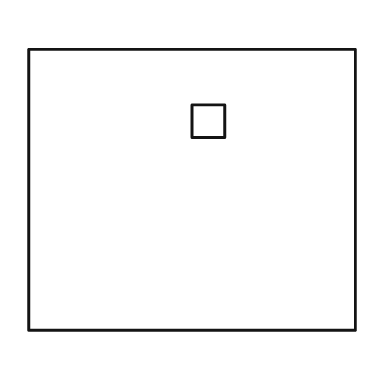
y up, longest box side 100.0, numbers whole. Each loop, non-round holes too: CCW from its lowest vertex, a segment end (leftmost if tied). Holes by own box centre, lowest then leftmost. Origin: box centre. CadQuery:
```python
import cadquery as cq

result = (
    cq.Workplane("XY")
    .moveTo(-50.0, -43.0)
    .lineTo(50.0, -43.0)
    .lineTo(50.0, 43.0)
    .lineTo(-50.0, 43.0)
    .close()
    .moveTo(0.0, 16.0)
    .lineTo(10.0, 16.0)
    .lineTo(10.0, 26.0)
    .lineTo(0.0, 26.0)
    .close()
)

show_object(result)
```